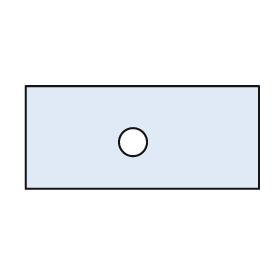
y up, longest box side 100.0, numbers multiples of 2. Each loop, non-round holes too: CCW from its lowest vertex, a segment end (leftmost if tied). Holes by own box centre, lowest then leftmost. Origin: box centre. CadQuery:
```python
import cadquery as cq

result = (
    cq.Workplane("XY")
    .moveTo(-50.0, -22.0)
    .lineTo(50.0, -22.0)
    .lineTo(50.0, 22.0)
    .lineTo(-50.0, 22.0)
    .close()
    .moveTo(-4.0, -2.0)
    .circle(6.0)
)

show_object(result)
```